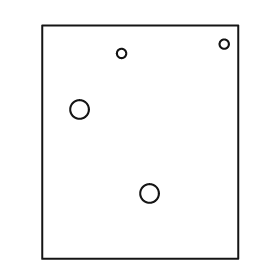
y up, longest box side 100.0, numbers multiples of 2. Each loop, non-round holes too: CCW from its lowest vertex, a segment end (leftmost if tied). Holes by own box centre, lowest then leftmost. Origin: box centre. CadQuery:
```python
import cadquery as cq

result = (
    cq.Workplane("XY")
    .moveTo(-42.0, -50.0)
    .lineTo(42.0, -50.0)
    .lineTo(42.0, 50.0)
    .lineTo(-42.0, 50.0)
    .close()
    .moveTo(4.0, -22.0)
    .circle(4.0)
    .moveTo(-26.0, 14.0)
    .circle(4.0)
    .moveTo(-8.0, 38.0)
    .circle(2.0)
    .moveTo(36.0, 42.0)
    .circle(2.0)
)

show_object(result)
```